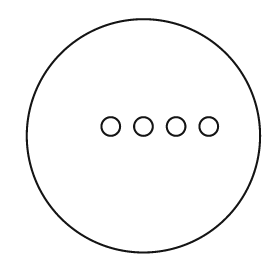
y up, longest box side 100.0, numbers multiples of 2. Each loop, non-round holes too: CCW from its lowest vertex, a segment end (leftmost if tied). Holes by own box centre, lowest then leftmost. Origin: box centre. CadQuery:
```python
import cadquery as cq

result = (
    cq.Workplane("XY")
    .moveTo(0.0, 0.0)
    .circle(50.0)
    .moveTo(-14.0, 4.0)
    .circle(4.0)
    .moveTo(0.0, 4.0)
    .circle(4.0)
    .moveTo(14.0, 4.0)
    .circle(4.0)
    .moveTo(28.0, 4.0)
    .circle(4.0)
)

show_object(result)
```